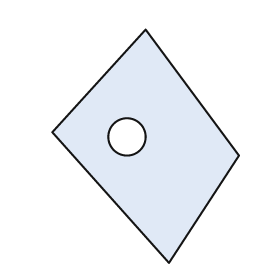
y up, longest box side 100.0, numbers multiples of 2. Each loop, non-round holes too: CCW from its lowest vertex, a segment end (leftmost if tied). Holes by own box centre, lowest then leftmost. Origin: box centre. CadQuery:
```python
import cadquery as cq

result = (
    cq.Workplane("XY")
    .moveTo(10.0, -50.0)
    .lineTo(40.0, -4.0)
    .lineTo(0.0, 50.0)
    .lineTo(-40.0, 6.0)
    .close()
    .moveTo(-8.0, 4.0)
    .circle(8.0)
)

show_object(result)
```